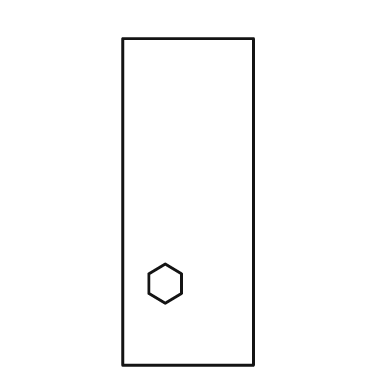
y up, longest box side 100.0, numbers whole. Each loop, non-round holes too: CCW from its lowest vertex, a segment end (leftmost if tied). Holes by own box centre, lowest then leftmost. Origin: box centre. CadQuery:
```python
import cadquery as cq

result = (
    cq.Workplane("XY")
    .moveTo(-20.0, -50.0)
    .lineTo(20.0, -50.0)
    .lineTo(20.0, 50.0)
    .lineTo(-20.0, 50.0)
    .close()
    .moveTo(-7.0, -31.0)
    .lineTo(-2.0, -28.0)
    .lineTo(-2.0, -22.0)
    .lineTo(-7.0, -19.0)
    .lineTo(-12.0, -22.0)
    .lineTo(-12.0, -28.0)
    .close()
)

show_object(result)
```